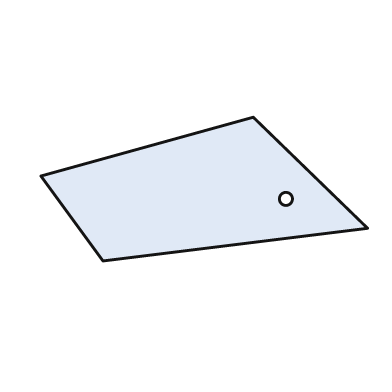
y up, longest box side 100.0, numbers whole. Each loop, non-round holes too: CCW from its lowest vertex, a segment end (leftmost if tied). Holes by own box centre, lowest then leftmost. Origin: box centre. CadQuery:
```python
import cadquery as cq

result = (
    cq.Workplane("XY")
    .moveTo(-31.0, -22.0)
    .lineTo(50.0, -12.0)
    .lineTo(15.0, 22.0)
    .lineTo(-50.0, 4.0)
    .close()
    .moveTo(25.0, -3.0)
    .circle(2.0)
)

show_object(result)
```